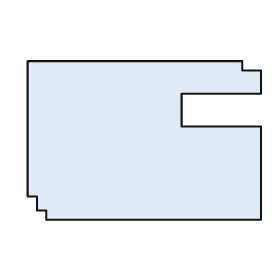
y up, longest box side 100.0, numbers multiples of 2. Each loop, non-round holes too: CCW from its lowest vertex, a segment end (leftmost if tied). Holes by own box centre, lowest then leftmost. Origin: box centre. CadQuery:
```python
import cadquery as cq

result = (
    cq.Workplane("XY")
    .moveTo(-42.0, -34.0)
    .lineTo(50.0, -34.0)
    .lineTo(50.0, 6.0)
    .lineTo(16.0, 6.0)
    .lineTo(16.0, 20.0)
    .lineTo(50.0, 20.0)
    .lineTo(50.0, 30.0)
    .lineTo(42.0, 30.0)
    .lineTo(42.0, 34.0)
    .lineTo(-50.0, 34.0)
    .lineTo(-50.0, -24.0)
    .lineTo(-46.0, -24.0)
    .lineTo(-46.0, -30.0)
    .lineTo(-42.0, -30.0)
    .close()
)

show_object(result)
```